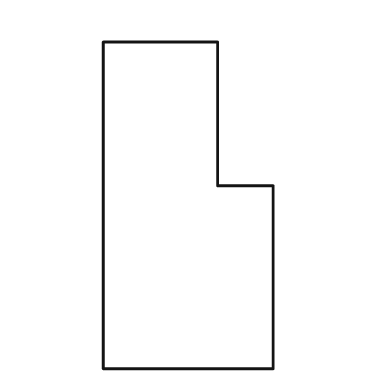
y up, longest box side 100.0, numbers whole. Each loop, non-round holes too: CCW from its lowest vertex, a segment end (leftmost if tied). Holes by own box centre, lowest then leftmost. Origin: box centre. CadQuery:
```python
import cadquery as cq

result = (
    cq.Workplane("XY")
    .moveTo(-26.0, -50.0)
    .lineTo(26.0, -50.0)
    .lineTo(26.0, 6.0)
    .lineTo(9.0, 6.0)
    .lineTo(9.0, 50.0)
    .lineTo(-26.0, 50.0)
    .close()
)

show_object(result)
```